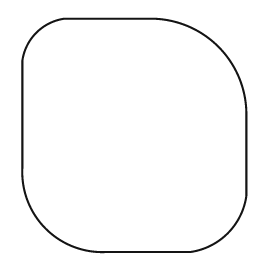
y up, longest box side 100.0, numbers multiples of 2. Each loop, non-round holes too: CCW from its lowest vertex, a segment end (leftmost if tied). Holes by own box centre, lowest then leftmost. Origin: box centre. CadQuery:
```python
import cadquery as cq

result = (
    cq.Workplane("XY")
    .moveTo(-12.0, -50.0)
    .lineTo(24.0, -50.0)
    .threePointArc((40.0, -42.0), (48.0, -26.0))
    .lineTo(48.0, 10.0)
    .threePointArc((36.0, 38.0), (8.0, 50.0))
    .lineTo(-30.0, 50.0)
    .threePointArc((-42.0, 44.0), (-48.0, 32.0))
    .lineTo(-48.0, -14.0)
    .threePointArc((-38.0, -40.0), (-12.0, -50.0))
    .close()
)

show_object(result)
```